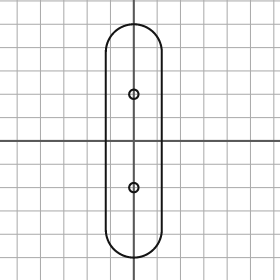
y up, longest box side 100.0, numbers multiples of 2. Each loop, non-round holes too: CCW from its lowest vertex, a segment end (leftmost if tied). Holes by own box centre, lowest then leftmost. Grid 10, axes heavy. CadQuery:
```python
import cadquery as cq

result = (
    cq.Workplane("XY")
    .moveTo(-12.0, -38.0)
    .threePointArc((0.0, -50.0), (12.0, -38.0))
    .lineTo(12.0, 38.0)
    .threePointArc((0.0, 50.0), (-12.0, 38.0))
    .close()
    .moveTo(0.0, -20.0)
    .circle(2.0)
    .moveTo(0.0, 20.0)
    .circle(2.0)
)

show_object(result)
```